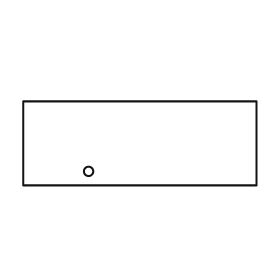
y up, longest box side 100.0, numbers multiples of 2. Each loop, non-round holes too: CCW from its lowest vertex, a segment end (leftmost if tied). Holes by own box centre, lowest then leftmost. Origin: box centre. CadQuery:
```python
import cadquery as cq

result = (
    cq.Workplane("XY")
    .moveTo(-50.0, -18.0)
    .lineTo(50.0, -18.0)
    .lineTo(50.0, 18.0)
    .lineTo(-50.0, 18.0)
    .close()
    .moveTo(-22.0, -12.0)
    .circle(2.0)
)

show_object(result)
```